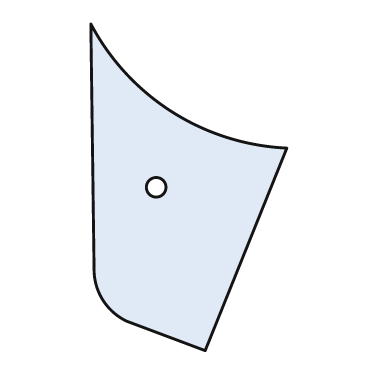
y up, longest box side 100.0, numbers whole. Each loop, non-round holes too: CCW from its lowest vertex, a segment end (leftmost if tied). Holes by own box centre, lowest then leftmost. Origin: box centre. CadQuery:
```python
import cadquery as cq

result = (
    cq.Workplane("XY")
    .moveTo(5.0, -50.0)
    .lineTo(30.0, 12.0)
    .threePointArc((-5.0, 23.0), (-30.0, 50.0))
    .lineTo(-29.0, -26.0)
    .threePointArc((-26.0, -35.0), (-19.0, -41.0))
    .close()
    .moveTo(-10.0, 0.0)
    .circle(3.0)
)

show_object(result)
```